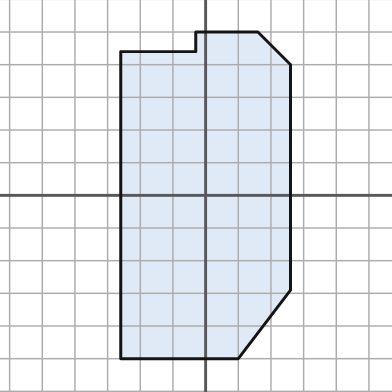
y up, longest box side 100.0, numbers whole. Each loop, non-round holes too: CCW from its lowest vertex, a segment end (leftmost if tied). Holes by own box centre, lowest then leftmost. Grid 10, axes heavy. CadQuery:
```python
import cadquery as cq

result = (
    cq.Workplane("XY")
    .moveTo(-26.0, -50.0)
    .lineTo(10.0, -50.0)
    .lineTo(26.0, -29.0)
    .lineTo(26.0, 40.0)
    .lineTo(16.0, 50.0)
    .lineTo(-3.0, 50.0)
    .lineTo(-3.0, 44.0)
    .lineTo(-26.0, 44.0)
    .close()
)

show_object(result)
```